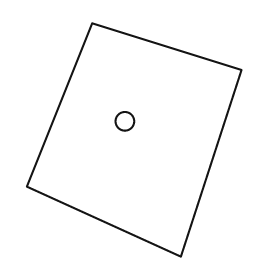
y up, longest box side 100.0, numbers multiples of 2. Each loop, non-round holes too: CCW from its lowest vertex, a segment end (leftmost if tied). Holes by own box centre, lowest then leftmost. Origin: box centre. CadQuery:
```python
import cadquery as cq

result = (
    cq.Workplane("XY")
    .moveTo(20.0, -50.0)
    .lineTo(46.0, 30.0)
    .lineTo(-18.0, 50.0)
    .lineTo(-46.0, -20.0)
    .close()
    .moveTo(-4.0, 8.0)
    .circle(4.0)
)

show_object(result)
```